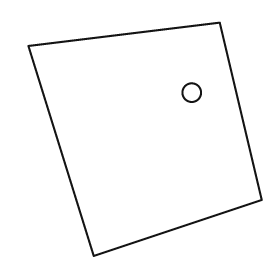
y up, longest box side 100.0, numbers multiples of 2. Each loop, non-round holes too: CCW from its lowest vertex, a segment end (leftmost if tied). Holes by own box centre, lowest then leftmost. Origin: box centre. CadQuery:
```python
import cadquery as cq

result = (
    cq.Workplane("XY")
    .moveTo(-22.0, -50.0)
    .lineTo(50.0, -26.0)
    .lineTo(32.0, 50.0)
    .lineTo(-50.0, 40.0)
    .close()
    .moveTo(20.0, 20.0)
    .circle(4.0)
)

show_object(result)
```